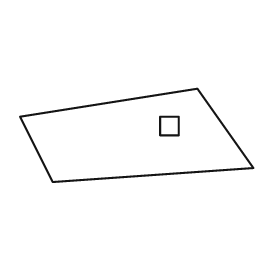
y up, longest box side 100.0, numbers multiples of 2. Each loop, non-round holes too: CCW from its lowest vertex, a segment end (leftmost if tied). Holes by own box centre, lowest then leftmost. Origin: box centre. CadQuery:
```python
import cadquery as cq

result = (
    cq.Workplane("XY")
    .moveTo(-36.0, -20.0)
    .lineTo(50.0, -14.0)
    .lineTo(26.0, 20.0)
    .lineTo(-50.0, 8.0)
    .close()
    .moveTo(10.0, 0.0)
    .lineTo(18.0, 0.0)
    .lineTo(18.0, 8.0)
    .lineTo(10.0, 8.0)
    .close()
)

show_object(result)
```